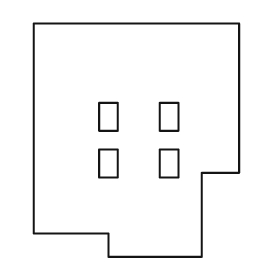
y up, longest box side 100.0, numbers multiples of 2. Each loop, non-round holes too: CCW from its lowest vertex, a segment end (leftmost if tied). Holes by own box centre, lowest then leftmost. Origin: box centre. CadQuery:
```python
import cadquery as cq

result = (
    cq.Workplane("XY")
    .moveTo(-12.0, -50.0)
    .lineTo(28.0, -50.0)
    .lineTo(28.0, -14.0)
    .lineTo(44.0, -14.0)
    .lineTo(44.0, 50.0)
    .lineTo(-44.0, 50.0)
    .lineTo(-44.0, -40.0)
    .lineTo(-12.0, -40.0)
    .close()
    .moveTo(-16.0, -16.0)
    .lineTo(-8.0, -16.0)
    .lineTo(-8.0, -4.0)
    .lineTo(-16.0, -4.0)
    .close()
    .moveTo(10.0, -16.0)
    .lineTo(18.0, -16.0)
    .lineTo(18.0, -4.0)
    .lineTo(10.0, -4.0)
    .close()
    .moveTo(-16.0, 4.0)
    .lineTo(-8.0, 4.0)
    .lineTo(-8.0, 16.0)
    .lineTo(-16.0, 16.0)
    .close()
    .moveTo(10.0, 4.0)
    .lineTo(18.0, 4.0)
    .lineTo(18.0, 16.0)
    .lineTo(10.0, 16.0)
    .close()
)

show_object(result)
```